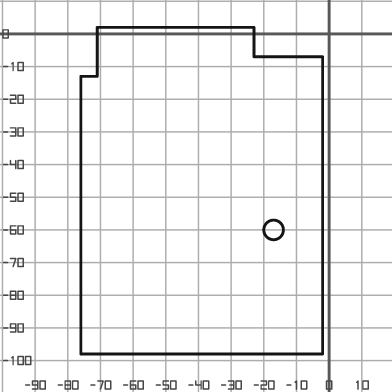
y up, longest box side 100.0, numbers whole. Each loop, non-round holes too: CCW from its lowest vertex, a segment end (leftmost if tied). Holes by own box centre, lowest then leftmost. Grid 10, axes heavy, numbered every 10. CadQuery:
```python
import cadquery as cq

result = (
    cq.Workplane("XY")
    .moveTo(-76.0, -98.0)
    .lineTo(-2.0, -98.0)
    .lineTo(-2.0, -7.0)
    .lineTo(-23.0, -7.0)
    .lineTo(-23.0, 2.0)
    .lineTo(-71.0, 2.0)
    .lineTo(-71.0, -13.0)
    .lineTo(-76.0, -13.0)
    .close()
    .moveTo(-17.0, -60.0)
    .circle(3.0)
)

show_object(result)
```